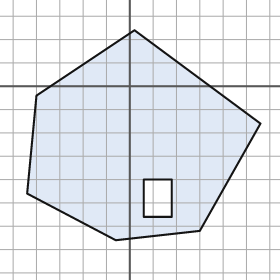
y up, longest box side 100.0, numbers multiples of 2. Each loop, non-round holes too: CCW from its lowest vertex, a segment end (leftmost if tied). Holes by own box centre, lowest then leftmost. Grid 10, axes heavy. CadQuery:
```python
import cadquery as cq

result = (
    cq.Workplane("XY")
    .moveTo(-6.0, -66.0)
    .lineTo(30.0, -62.0)
    .lineTo(56.0, -16.0)
    .lineTo(2.0, 24.0)
    .lineTo(-40.0, -4.0)
    .lineTo(-44.0, -46.0)
    .close()
    .moveTo(6.0, -56.0)
    .lineTo(18.0, -56.0)
    .lineTo(18.0, -40.0)
    .lineTo(6.0, -40.0)
    .close()
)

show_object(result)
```